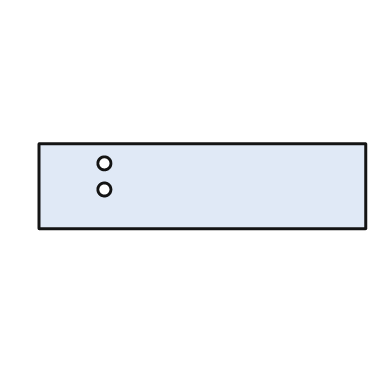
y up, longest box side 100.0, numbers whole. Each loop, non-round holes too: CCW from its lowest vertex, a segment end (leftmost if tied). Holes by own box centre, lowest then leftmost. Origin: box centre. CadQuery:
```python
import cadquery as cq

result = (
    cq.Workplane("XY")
    .moveTo(-50.0, -13.0)
    .lineTo(50.0, -13.0)
    .lineTo(50.0, 13.0)
    .lineTo(-50.0, 13.0)
    .close()
    .moveTo(-30.0, -1.0)
    .circle(2.0)
    .moveTo(-30.0, 7.0)
    .circle(2.0)
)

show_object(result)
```